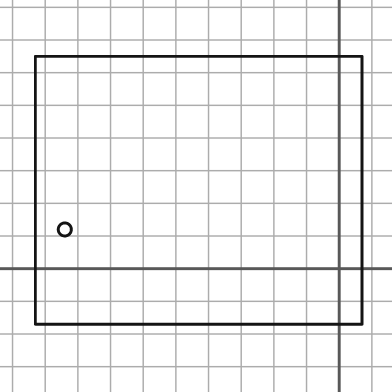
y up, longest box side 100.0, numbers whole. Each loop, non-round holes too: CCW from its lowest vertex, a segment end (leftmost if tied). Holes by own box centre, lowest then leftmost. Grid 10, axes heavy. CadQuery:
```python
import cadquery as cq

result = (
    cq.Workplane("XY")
    .moveTo(-93.0, -17.0)
    .lineTo(7.0, -17.0)
    .lineTo(7.0, 65.0)
    .lineTo(-93.0, 65.0)
    .close()
    .moveTo(-84.0, 12.0)
    .circle(2.0)
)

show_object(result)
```